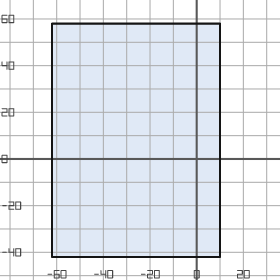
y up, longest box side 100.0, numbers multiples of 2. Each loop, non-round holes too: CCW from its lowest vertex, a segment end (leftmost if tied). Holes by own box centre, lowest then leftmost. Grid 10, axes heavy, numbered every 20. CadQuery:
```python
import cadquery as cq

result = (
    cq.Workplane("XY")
    .moveTo(-62.0, -42.0)
    .lineTo(10.0, -42.0)
    .lineTo(10.0, 58.0)
    .lineTo(-62.0, 58.0)
    .close()
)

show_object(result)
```